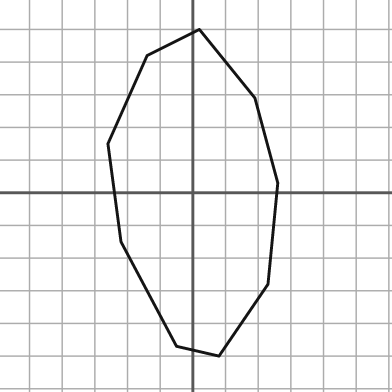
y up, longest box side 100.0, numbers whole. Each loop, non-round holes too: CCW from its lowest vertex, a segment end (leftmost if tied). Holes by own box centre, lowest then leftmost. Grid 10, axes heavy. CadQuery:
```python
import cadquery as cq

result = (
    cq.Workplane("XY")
    .moveTo(8.0, -50.0)
    .lineTo(23.0, -28.0)
    .lineTo(26.0, 3.0)
    .lineTo(19.0, 29.0)
    .lineTo(2.0, 50.0)
    .lineTo(-14.0, 42.0)
    .lineTo(-26.0, 15.0)
    .lineTo(-22.0, -15.0)
    .lineTo(-5.0, -47.0)
    .close()
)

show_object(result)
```